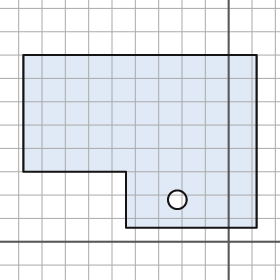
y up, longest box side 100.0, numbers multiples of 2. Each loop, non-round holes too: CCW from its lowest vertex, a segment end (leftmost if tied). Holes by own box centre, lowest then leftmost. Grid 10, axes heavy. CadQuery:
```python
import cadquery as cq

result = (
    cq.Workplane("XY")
    .moveTo(-44.0, 6.0)
    .lineTo(12.0, 6.0)
    .lineTo(12.0, 80.0)
    .lineTo(-88.0, 80.0)
    .lineTo(-88.0, 30.0)
    .lineTo(-44.0, 30.0)
    .close()
    .moveTo(-22.0, 18.0)
    .circle(4.0)
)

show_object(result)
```